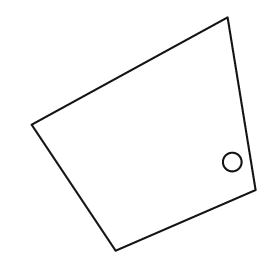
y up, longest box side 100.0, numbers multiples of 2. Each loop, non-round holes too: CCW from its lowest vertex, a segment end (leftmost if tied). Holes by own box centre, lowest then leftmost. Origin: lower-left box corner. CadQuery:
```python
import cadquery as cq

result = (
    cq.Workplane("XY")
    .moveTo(36.0, 0.0)
    .lineTo(96.0, 26.0)
    .lineTo(84.0, 100.0)
    .lineTo(0.0, 54.0)
    .close()
    .moveTo(86.0, 38.0)
    .circle(4.0)
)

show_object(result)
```